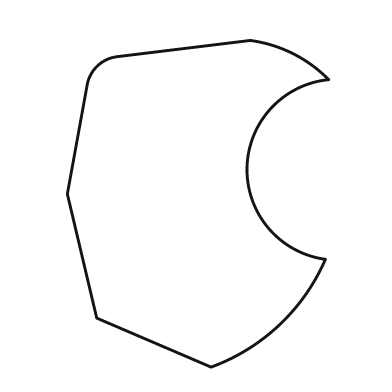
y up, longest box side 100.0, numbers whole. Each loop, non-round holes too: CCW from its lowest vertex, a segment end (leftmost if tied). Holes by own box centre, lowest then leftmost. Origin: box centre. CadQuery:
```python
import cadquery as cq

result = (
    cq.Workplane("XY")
    .moveTo(4.0, -50.0)
    .threePointArc((25.0, -37.0), (39.0, -17.0))
    .threePointArc((15.0, 11.0), (40.0, 38.0))
    .threePointArc((29.0, 46.0), (16.0, 50.0))
    .lineTo(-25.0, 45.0)
    .threePointArc((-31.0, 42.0), (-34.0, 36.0))
    .lineTo(-40.0, 3.0)
    .lineTo(-31.0, -35.0)
    .close()
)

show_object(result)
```